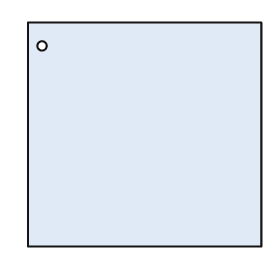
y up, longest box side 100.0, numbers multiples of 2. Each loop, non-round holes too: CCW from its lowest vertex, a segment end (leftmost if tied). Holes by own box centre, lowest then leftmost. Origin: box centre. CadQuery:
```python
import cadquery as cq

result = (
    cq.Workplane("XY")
    .moveTo(-50.0, -48.0)
    .lineTo(50.0, -48.0)
    .lineTo(50.0, 48.0)
    .lineTo(-50.0, 48.0)
    .close()
    .moveTo(-44.0, 38.0)
    .circle(2.0)
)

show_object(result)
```